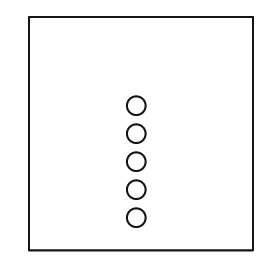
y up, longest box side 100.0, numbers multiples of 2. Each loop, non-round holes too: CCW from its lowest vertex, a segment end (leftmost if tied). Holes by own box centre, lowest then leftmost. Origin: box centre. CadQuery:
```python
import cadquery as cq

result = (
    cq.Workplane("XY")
    .moveTo(-48.0, -50.0)
    .lineTo(48.0, -50.0)
    .lineTo(48.0, 50.0)
    .lineTo(-48.0, 50.0)
    .close()
    .moveTo(-2.0, -36.0)
    .circle(4.0)
    .moveTo(-2.0, -24.0)
    .circle(4.0)
    .moveTo(-2.0, -12.0)
    .circle(4.0)
    .moveTo(-2.0, 0.0)
    .circle(4.0)
    .moveTo(-2.0, 12.0)
    .circle(4.0)
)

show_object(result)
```